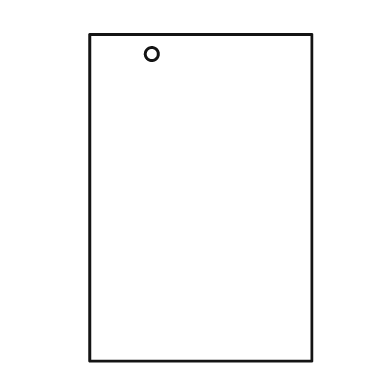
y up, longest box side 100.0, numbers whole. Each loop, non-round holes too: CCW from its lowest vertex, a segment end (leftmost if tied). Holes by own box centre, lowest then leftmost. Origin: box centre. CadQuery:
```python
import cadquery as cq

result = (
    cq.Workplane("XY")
    .moveTo(-34.0, -50.0)
    .lineTo(34.0, -50.0)
    .lineTo(34.0, 50.0)
    .lineTo(-34.0, 50.0)
    .close()
    .moveTo(-15.0, 44.0)
    .circle(2.0)
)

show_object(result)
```